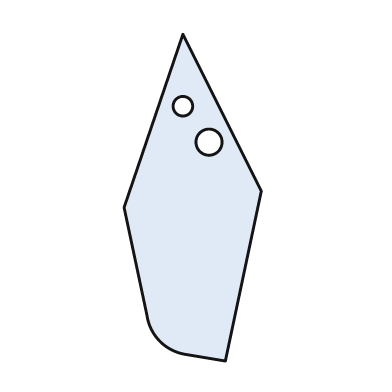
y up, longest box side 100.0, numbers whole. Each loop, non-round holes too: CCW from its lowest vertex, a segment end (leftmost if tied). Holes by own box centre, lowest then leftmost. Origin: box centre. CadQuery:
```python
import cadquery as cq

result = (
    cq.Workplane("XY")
    .moveTo(10.0, -50.0)
    .lineTo(21.0, 2.0)
    .lineTo(-3.0, 50.0)
    .lineTo(-21.0, -3.0)
    .lineTo(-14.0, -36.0)
    .threePointArc((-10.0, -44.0), (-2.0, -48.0))
    .close()
    .moveTo(5.0, 17.0)
    .circle(4.0)
    .moveTo(-3.0, 28.0)
    .circle(3.0)
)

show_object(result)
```